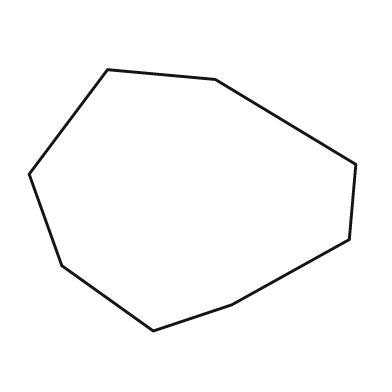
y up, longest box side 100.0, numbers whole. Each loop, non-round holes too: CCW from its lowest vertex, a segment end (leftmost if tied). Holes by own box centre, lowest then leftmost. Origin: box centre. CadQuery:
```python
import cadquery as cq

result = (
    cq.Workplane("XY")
    .moveTo(-12.0, -40.0)
    .lineTo(12.0, -32.0)
    .lineTo(48.0, -12.0)
    .lineTo(50.0, 11.0)
    .lineTo(7.0, 37.0)
    .lineTo(-26.0, 40.0)
    .lineTo(-50.0, 8.0)
    .lineTo(-40.0, -20.0)
    .close()
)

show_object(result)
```